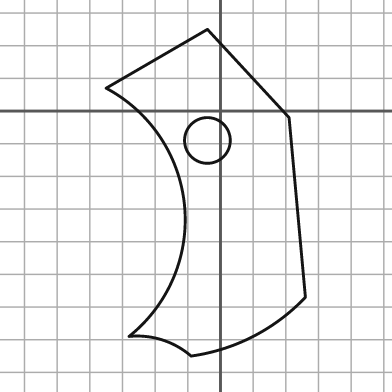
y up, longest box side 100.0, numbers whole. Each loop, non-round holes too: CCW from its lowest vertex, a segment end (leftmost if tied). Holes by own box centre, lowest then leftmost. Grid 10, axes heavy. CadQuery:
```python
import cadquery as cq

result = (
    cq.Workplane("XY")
    .moveTo(-9.0, -75.0)
    .threePointArc((10.0, -69.0), (26.0, -57.0))
    .lineTo(21.0, -2.0)
    .lineTo(-4.0, 25.0)
    .lineTo(-35.0, 7.0)
    .threePointArc((-11.0, -29.0), (-28.0, -69.0))
    .threePointArc((-18.0, -70.0), (-9.0, -75.0))
    .close()
    .moveTo(-4.0, -9.0)
    .circle(7.0)
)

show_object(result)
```